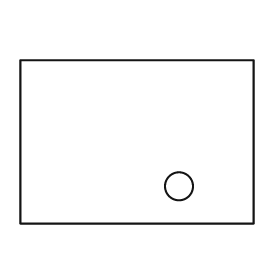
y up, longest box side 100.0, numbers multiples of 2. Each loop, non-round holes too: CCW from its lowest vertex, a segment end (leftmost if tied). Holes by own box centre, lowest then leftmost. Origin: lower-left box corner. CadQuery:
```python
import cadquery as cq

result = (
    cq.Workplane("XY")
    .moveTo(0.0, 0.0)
    .lineTo(100.0, 0.0)
    .lineTo(100.0, 70.0)
    .lineTo(0.0, 70.0)
    .close()
    .moveTo(68.0, 16.0)
    .circle(6.0)
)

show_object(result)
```